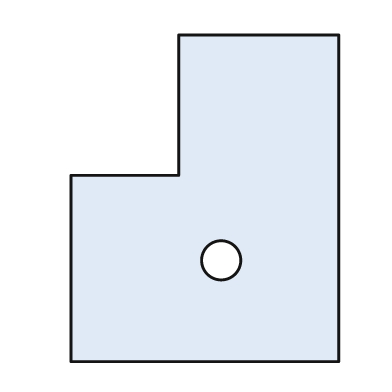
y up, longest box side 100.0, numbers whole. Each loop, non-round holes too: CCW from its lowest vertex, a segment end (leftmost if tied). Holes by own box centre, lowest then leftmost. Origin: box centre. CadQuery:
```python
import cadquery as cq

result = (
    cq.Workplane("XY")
    .moveTo(-41.0, -50.0)
    .lineTo(41.0, -50.0)
    .lineTo(41.0, 50.0)
    .lineTo(-8.0, 50.0)
    .lineTo(-8.0, 7.0)
    .lineTo(-41.0, 7.0)
    .close()
    .moveTo(5.0, -19.0)
    .circle(6.0)
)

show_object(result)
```